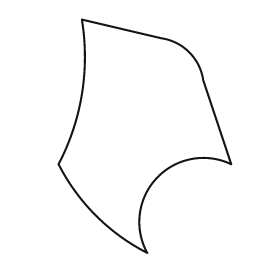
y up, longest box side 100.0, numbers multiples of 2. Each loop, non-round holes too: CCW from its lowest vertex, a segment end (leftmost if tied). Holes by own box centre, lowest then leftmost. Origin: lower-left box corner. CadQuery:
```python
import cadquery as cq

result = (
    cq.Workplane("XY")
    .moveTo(38.0, 0.0)
    .threePointArc((42.0, 32.0), (74.0, 38.0))
    .lineTo(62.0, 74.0)
    .threePointArc((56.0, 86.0), (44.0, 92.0))
    .lineTo(10.0, 100.0)
    .threePointArc((10.0, 68.0), (0.0, 38.0))
    .threePointArc((16.0, 16.0), (38.0, 0.0))
    .close()
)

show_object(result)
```